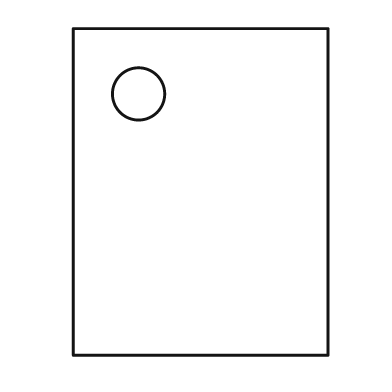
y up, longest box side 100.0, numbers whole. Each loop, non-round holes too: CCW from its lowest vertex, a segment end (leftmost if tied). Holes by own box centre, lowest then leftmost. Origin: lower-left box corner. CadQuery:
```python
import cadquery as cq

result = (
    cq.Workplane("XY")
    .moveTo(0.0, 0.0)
    .lineTo(78.0, 0.0)
    .lineTo(78.0, 100.0)
    .lineTo(0.0, 100.0)
    .close()
    .moveTo(20.0, 80.0)
    .circle(8.0)
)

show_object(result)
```